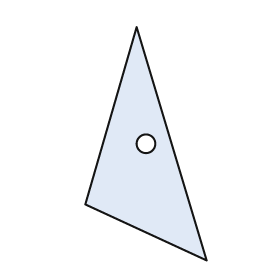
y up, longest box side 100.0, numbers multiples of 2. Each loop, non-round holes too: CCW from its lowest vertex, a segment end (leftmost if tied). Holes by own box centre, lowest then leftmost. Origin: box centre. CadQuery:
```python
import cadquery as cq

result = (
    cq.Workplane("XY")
    .moveTo(26.0, -50.0)
    .lineTo(-4.0, 50.0)
    .lineTo(-26.0, -26.0)
    .close()
    .moveTo(0.0, 0.0)
    .circle(4.0)
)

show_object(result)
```